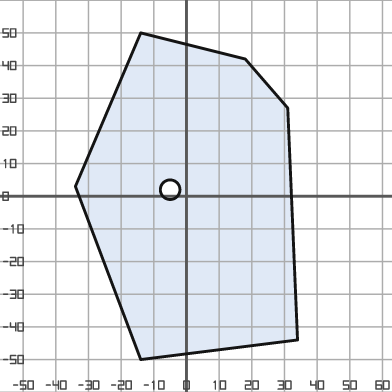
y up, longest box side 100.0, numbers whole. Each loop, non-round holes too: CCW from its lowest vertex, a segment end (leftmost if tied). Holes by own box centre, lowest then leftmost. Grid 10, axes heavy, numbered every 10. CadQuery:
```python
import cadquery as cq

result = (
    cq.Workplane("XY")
    .moveTo(-14.0, -50.0)
    .lineTo(34.0, -44.0)
    .lineTo(31.0, 27.0)
    .lineTo(18.0, 42.0)
    .lineTo(-14.0, 50.0)
    .lineTo(-34.0, 3.0)
    .close()
    .moveTo(-5.0, 2.0)
    .circle(3.0)
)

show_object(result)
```